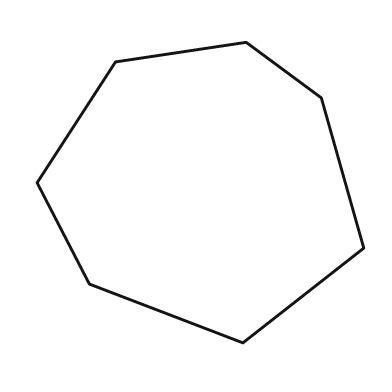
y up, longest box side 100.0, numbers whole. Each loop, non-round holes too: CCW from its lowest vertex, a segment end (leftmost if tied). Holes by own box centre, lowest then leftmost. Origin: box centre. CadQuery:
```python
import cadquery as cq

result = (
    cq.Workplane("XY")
    .moveTo(13.0, -46.0)
    .lineTo(50.0, -17.0)
    .lineTo(37.0, 29.0)
    .lineTo(14.0, 46.0)
    .lineTo(-26.0, 40.0)
    .lineTo(-50.0, 3.0)
    .lineTo(-34.0, -28.0)
    .close()
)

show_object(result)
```